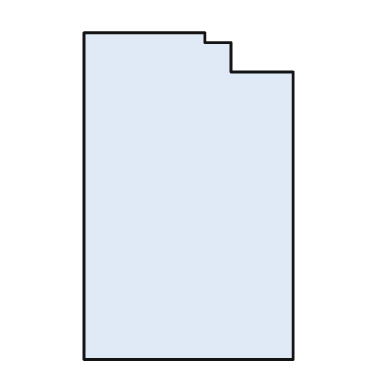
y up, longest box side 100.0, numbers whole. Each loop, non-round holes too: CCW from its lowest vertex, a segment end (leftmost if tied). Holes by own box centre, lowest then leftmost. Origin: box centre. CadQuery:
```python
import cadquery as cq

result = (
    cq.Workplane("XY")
    .moveTo(-32.0, -50.0)
    .lineTo(32.0, -50.0)
    .lineTo(32.0, 38.0)
    .lineTo(13.0, 38.0)
    .lineTo(13.0, 47.0)
    .lineTo(5.0, 47.0)
    .lineTo(5.0, 50.0)
    .lineTo(-32.0, 50.0)
    .close()
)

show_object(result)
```